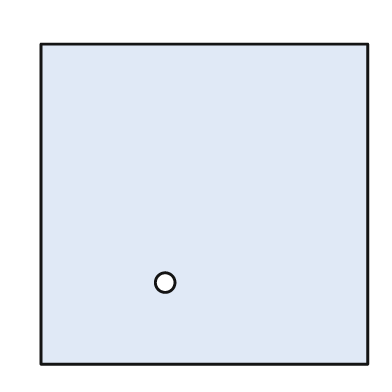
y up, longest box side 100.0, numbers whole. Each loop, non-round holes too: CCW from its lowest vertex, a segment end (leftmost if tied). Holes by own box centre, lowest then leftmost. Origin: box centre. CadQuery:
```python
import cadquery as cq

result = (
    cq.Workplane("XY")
    .moveTo(-50.0, -49.0)
    .lineTo(50.0, -49.0)
    .lineTo(50.0, 49.0)
    .lineTo(-50.0, 49.0)
    .close()
    .moveTo(-12.0, -24.0)
    .circle(3.0)
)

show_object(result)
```